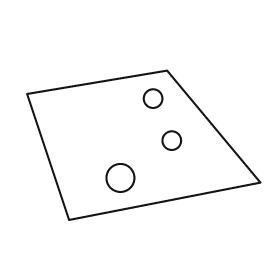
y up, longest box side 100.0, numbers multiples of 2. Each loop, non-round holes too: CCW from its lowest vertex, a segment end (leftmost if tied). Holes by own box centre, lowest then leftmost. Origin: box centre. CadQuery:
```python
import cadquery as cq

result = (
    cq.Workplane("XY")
    .moveTo(-32.0, -32.0)
    .lineTo(50.0, -16.0)
    .lineTo(10.0, 32.0)
    .lineTo(-50.0, 22.0)
    .close()
    .moveTo(-10.0, -14.0)
    .circle(6.0)
    .moveTo(12.0, 2.0)
    .circle(4.0)
    .moveTo(4.0, 20.0)
    .circle(4.0)
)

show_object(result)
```